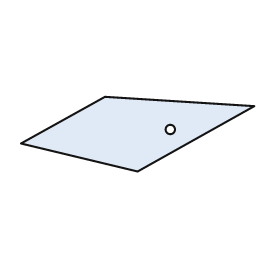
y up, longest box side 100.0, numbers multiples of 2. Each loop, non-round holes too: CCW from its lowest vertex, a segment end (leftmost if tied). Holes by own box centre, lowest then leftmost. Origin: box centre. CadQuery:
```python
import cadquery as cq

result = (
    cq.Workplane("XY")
    .moveTo(0.0, -16.0)
    .lineTo(50.0, 12.0)
    .lineTo(-14.0, 16.0)
    .lineTo(-50.0, -4.0)
    .close()
    .moveTo(14.0, 2.0)
    .circle(2.0)
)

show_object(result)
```